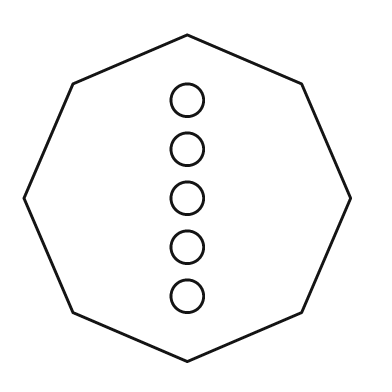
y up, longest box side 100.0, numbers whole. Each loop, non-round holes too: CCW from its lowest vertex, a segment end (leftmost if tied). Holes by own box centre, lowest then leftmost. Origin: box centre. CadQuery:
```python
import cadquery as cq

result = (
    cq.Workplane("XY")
    .moveTo(0.0, -50.0)
    .lineTo(35.0, -35.0)
    .lineTo(50.0, 0.0)
    .lineTo(35.0, 35.0)
    .lineTo(0.0, 50.0)
    .lineTo(-35.0, 35.0)
    .lineTo(-50.0, 0.0)
    .lineTo(-35.0, -35.0)
    .close()
    .moveTo(0.0, -30.0)
    .circle(5.0)
    .moveTo(0.0, -15.0)
    .circle(5.0)
    .moveTo(0.0, 0.0)
    .circle(5.0)
    .moveTo(0.0, 15.0)
    .circle(5.0)
    .moveTo(0.0, 30.0)
    .circle(5.0)
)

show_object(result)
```